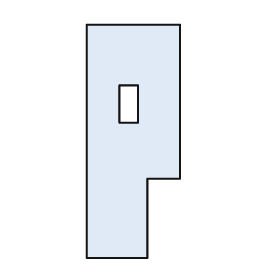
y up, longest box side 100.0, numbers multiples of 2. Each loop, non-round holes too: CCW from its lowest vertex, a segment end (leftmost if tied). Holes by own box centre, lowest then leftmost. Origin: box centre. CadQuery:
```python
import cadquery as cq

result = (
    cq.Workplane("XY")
    .moveTo(-20.0, -50.0)
    .lineTo(6.0, -50.0)
    .lineTo(6.0, -16.0)
    .lineTo(20.0, -16.0)
    .lineTo(20.0, 50.0)
    .lineTo(-20.0, 50.0)
    .close()
    .moveTo(-6.0, 8.0)
    .lineTo(2.0, 8.0)
    .lineTo(2.0, 24.0)
    .lineTo(-6.0, 24.0)
    .close()
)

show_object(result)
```